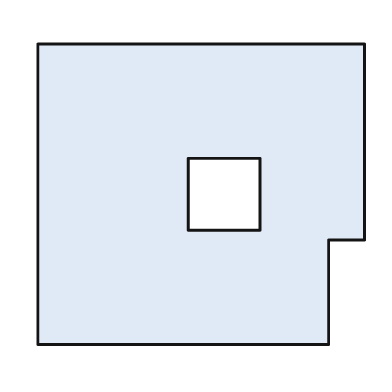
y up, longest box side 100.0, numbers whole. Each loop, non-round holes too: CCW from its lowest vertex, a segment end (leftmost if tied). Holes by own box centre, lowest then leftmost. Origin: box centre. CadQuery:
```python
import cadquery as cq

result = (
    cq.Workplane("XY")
    .moveTo(-50.0, -46.0)
    .lineTo(39.0, -46.0)
    .lineTo(39.0, -14.0)
    .lineTo(50.0, -14.0)
    .lineTo(50.0, 46.0)
    .lineTo(-50.0, 46.0)
    .close()
    .moveTo(-4.0, -11.0)
    .lineTo(18.0, -11.0)
    .lineTo(18.0, 11.0)
    .lineTo(-4.0, 11.0)
    .close()
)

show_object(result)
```